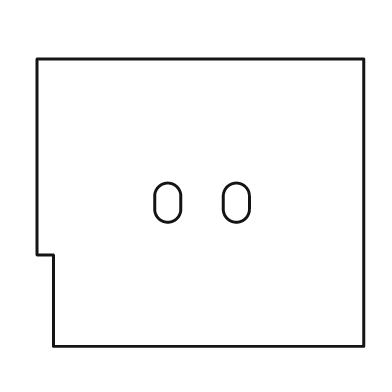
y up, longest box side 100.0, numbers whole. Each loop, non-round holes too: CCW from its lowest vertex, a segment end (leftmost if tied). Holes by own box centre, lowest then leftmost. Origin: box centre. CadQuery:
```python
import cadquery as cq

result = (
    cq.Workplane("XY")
    .moveTo(-45.0, -44.0)
    .lineTo(50.0, -44.0)
    .lineTo(50.0, 44.0)
    .lineTo(-50.0, 44.0)
    .lineTo(-50.0, -16.0)
    .lineTo(-45.0, -16.0)
    .close()
    .moveTo(-14.0, -2.0)
    .threePointArc((-10.0, -6.0), (-6.0, -2.0))
    .lineTo(-6.0, 2.0)
    .threePointArc((-10.0, 6.0), (-14.0, 2.0))
    .close()
    .moveTo(7.0, -2.0)
    .threePointArc((11.0, -6.0), (15.0, -2.0))
    .lineTo(15.0, 2.0)
    .threePointArc((11.0, 6.0), (7.0, 2.0))
    .close()
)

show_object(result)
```